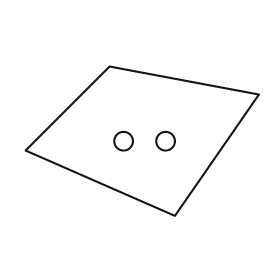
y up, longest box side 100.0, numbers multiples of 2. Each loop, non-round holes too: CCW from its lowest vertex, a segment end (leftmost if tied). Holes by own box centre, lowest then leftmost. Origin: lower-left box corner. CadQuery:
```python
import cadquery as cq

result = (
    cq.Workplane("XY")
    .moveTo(64.0, 0.0)
    .lineTo(100.0, 52.0)
    .lineTo(36.0, 64.0)
    .lineTo(0.0, 28.0)
    .close()
    .moveTo(42.0, 32.0)
    .circle(4.0)
    .moveTo(60.0, 32.0)
    .circle(4.0)
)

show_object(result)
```